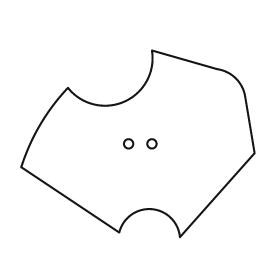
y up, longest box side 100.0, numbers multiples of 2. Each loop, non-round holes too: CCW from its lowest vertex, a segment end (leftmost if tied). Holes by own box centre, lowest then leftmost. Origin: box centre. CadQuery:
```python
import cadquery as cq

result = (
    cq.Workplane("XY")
    .moveTo(18.0, -40.0)
    .lineTo(50.0, -4.0)
    .lineTo(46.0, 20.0)
    .threePointArc((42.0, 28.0), (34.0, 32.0))
    .lineTo(6.0, 40.0)
    .threePointArc((-6.0, 18.0), (-30.0, 24.0))
    .threePointArc((-42.0, 8.0), (-50.0, -10.0))
    .lineTo(-8.0, -38.0)
    .threePointArc((6.0, -28.0), (18.0, -40.0))
    .close()
    .moveTo(-4.0, 0.0)
    .circle(2.0)
    .moveTo(6.0, 0.0)
    .circle(2.0)
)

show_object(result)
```